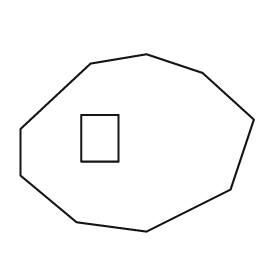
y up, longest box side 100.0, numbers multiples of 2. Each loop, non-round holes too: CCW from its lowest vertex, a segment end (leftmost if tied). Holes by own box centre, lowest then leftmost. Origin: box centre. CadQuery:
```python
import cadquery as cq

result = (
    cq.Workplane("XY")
    .moveTo(4.0, -38.0)
    .lineTo(40.0, -20.0)
    .lineTo(50.0, 10.0)
    .lineTo(28.0, 30.0)
    .lineTo(4.0, 38.0)
    .lineTo(-20.0, 34.0)
    .lineTo(-50.0, 6.0)
    .lineTo(-50.0, -14.0)
    .lineTo(-26.0, -34.0)
    .close()
    .moveTo(-24.0, -8.0)
    .lineTo(-8.0, -8.0)
    .lineTo(-8.0, 12.0)
    .lineTo(-24.0, 12.0)
    .close()
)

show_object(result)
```